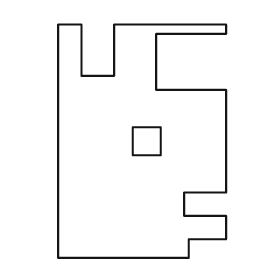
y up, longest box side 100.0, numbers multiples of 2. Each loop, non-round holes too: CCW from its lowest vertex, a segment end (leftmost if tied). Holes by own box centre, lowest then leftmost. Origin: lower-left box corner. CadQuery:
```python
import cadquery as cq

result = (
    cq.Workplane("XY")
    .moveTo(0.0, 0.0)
    .lineTo(56.0, 0.0)
    .lineTo(56.0, 8.0)
    .lineTo(72.0, 8.0)
    .lineTo(72.0, 18.0)
    .lineTo(54.0, 18.0)
    .lineTo(54.0, 28.0)
    .lineTo(72.0, 28.0)
    .lineTo(72.0, 72.0)
    .lineTo(42.0, 72.0)
    .lineTo(42.0, 96.0)
    .lineTo(72.0, 96.0)
    .lineTo(72.0, 100.0)
    .lineTo(24.0, 100.0)
    .lineTo(24.0, 78.0)
    .lineTo(10.0, 78.0)
    .lineTo(10.0, 100.0)
    .lineTo(0.0, 100.0)
    .close()
    .moveTo(32.0, 44.0)
    .lineTo(44.0, 44.0)
    .lineTo(44.0, 56.0)
    .lineTo(32.0, 56.0)
    .close()
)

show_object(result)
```